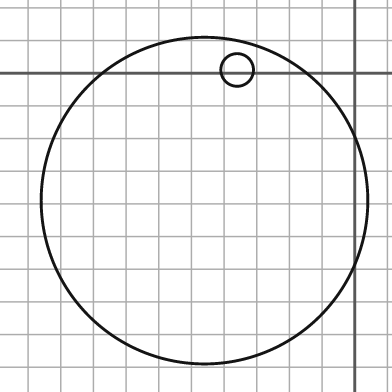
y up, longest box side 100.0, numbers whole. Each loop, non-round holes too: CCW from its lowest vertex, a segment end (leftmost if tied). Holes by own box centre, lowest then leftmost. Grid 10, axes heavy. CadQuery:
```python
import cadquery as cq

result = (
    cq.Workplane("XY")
    .moveTo(-46.0, -39.0)
    .circle(50.0)
    .moveTo(-36.0, 1.0)
    .circle(5.0)
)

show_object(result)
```